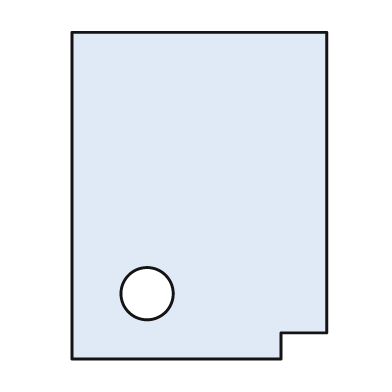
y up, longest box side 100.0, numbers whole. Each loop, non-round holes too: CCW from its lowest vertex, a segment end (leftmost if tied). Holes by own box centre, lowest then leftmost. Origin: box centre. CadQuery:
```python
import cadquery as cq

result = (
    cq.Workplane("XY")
    .moveTo(-39.0, -50.0)
    .lineTo(25.0, -50.0)
    .lineTo(25.0, -42.0)
    .lineTo(39.0, -42.0)
    .lineTo(39.0, 50.0)
    .lineTo(-39.0, 50.0)
    .close()
    .moveTo(-16.0, -30.0)
    .circle(8.0)
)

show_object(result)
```